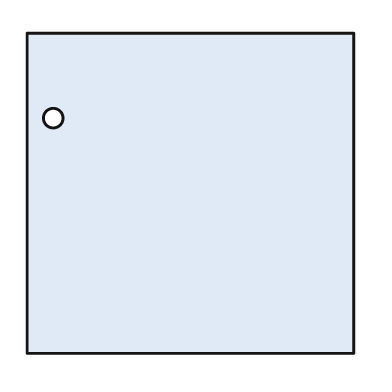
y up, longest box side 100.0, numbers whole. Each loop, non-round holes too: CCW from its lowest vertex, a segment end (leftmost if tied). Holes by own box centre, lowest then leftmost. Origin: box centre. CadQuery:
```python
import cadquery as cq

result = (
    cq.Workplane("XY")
    .moveTo(-50.0, -49.0)
    .lineTo(50.0, -49.0)
    .lineTo(50.0, 49.0)
    .lineTo(-50.0, 49.0)
    .close()
    .moveTo(-42.0, 23.0)
    .circle(3.0)
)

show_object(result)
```